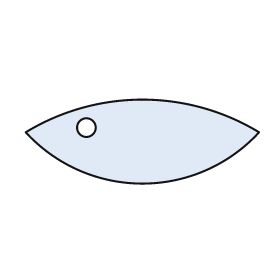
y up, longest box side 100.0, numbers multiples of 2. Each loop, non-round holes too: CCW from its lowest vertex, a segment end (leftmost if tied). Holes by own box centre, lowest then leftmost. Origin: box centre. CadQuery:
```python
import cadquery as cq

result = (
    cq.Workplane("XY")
    .moveTo(-50.0, 4.0)
    .threePointArc((0.0, -18.0), (50.0, 4.0))
    .threePointArc((0.0, 18.0), (-50.0, 4.0))
    .close()
    .moveTo(-24.0, 6.0)
    .circle(4.0)
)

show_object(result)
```